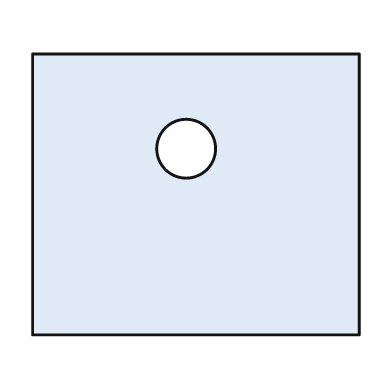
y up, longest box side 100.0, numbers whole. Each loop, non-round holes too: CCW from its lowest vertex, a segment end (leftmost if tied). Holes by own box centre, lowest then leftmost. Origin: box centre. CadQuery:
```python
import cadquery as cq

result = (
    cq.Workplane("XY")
    .moveTo(-50.0, -43.0)
    .lineTo(50.0, -43.0)
    .lineTo(50.0, 43.0)
    .lineTo(-50.0, 43.0)
    .close()
    .moveTo(-3.0, 14.0)
    .circle(9.0)
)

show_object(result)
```